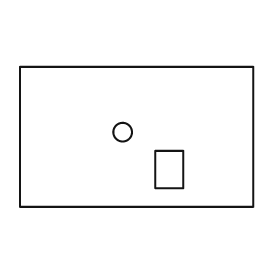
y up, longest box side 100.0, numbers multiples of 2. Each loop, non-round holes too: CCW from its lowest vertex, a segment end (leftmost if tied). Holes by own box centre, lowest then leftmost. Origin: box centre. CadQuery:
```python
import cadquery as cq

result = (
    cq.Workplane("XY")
    .moveTo(-50.0, -30.0)
    .lineTo(50.0, -30.0)
    .lineTo(50.0, 30.0)
    .lineTo(-50.0, 30.0)
    .close()
    .moveTo(8.0, -22.0)
    .lineTo(20.0, -22.0)
    .lineTo(20.0, -6.0)
    .lineTo(8.0, -6.0)
    .close()
    .moveTo(-6.0, 2.0)
    .circle(4.0)
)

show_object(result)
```